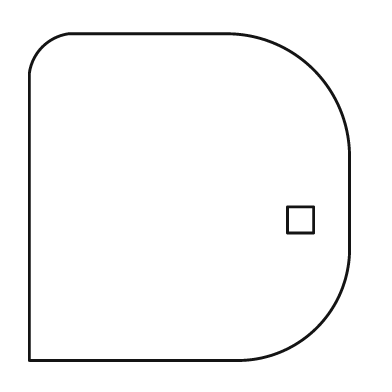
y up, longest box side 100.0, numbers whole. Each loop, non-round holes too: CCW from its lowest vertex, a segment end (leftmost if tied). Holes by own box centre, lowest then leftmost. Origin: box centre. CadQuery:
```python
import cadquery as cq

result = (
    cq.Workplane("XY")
    .moveTo(-49.0, -50.0)
    .lineTo(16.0, -50.0)
    .threePointArc((39.0, -40.0), (49.0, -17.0))
    .lineTo(49.0, 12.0)
    .threePointArc((38.0, 39.0), (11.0, 50.0))
    .lineTo(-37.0, 50.0)
    .threePointArc((-45.0, 46.0), (-49.0, 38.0))
    .close()
    .moveTo(30.0, -11.0)
    .lineTo(38.0, -11.0)
    .lineTo(38.0, -3.0)
    .lineTo(30.0, -3.0)
    .close()
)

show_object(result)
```